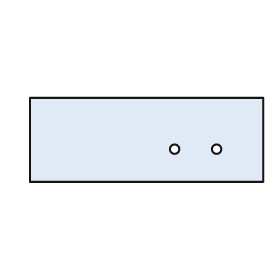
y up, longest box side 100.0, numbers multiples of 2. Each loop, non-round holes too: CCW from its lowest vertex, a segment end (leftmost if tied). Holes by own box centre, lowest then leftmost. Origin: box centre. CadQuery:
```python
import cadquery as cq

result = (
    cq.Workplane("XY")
    .moveTo(-50.0, -18.0)
    .lineTo(50.0, -18.0)
    .lineTo(50.0, 18.0)
    .lineTo(-50.0, 18.0)
    .close()
    .moveTo(12.0, -4.0)
    .circle(2.0)
    .moveTo(30.0, -4.0)
    .circle(2.0)
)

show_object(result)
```